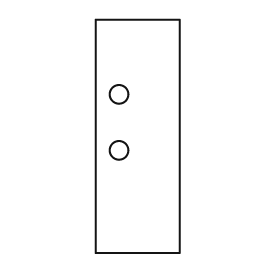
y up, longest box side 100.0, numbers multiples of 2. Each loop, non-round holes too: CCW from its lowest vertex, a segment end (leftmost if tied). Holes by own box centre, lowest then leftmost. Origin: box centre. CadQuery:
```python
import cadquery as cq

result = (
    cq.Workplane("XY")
    .moveTo(-18.0, -50.0)
    .lineTo(18.0, -50.0)
    .lineTo(18.0, 50.0)
    .lineTo(-18.0, 50.0)
    .close()
    .moveTo(-8.0, -6.0)
    .circle(4.0)
    .moveTo(-8.0, 18.0)
    .circle(4.0)
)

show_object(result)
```